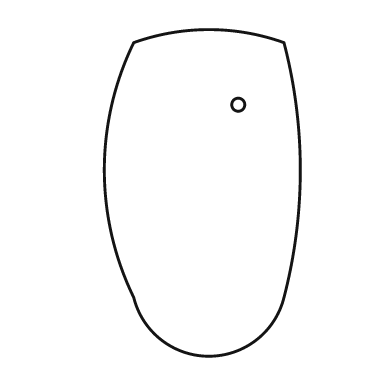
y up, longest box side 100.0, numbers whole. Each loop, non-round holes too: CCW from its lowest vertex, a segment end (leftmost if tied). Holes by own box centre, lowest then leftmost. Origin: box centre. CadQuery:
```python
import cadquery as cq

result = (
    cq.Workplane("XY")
    .moveTo(-21.0, -32.0)
    .threePointArc((2.0, -50.0), (25.0, -32.0))
    .threePointArc((30.0, 7.0), (25.0, 46.0))
    .threePointArc((2.0, 50.0), (-21.0, 46.0))
    .threePointArc((-30.0, 7.0), (-21.0, -32.0))
    .close()
    .moveTo(11.0, 27.0)
    .circle(2.0)
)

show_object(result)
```